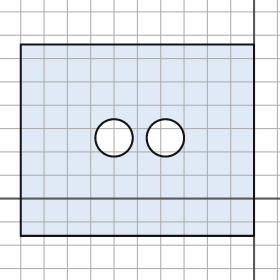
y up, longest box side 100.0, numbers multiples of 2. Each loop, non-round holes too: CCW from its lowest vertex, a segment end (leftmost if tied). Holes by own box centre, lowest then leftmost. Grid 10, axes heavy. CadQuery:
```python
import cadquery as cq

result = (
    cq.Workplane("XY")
    .moveTo(-100.0, -16.0)
    .lineTo(0.0, -16.0)
    .lineTo(0.0, 66.0)
    .lineTo(-100.0, 66.0)
    .close()
    .moveTo(-60.0, 26.0)
    .circle(8.0)
    .moveTo(-38.0, 26.0)
    .circle(8.0)
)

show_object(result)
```